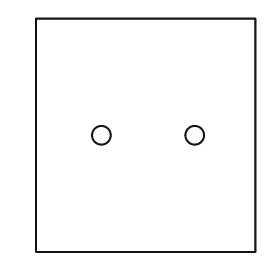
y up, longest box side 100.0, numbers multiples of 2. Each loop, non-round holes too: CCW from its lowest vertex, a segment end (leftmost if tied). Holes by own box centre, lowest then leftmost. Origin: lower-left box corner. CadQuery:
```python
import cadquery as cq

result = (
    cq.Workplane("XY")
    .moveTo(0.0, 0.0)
    .lineTo(94.0, 0.0)
    .lineTo(94.0, 100.0)
    .lineTo(0.0, 100.0)
    .close()
    .moveTo(28.0, 50.0)
    .circle(4.0)
    .moveTo(68.0, 50.0)
    .circle(4.0)
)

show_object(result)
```